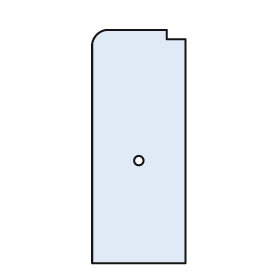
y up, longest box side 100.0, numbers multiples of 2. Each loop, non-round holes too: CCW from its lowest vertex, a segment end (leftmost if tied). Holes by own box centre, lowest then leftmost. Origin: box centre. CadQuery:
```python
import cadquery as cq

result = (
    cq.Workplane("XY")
    .moveTo(-20.0, -50.0)
    .lineTo(20.0, -50.0)
    .lineTo(20.0, 46.0)
    .lineTo(12.0, 46.0)
    .lineTo(12.0, 50.0)
    .lineTo(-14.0, 50.0)
    .threePointArc((-18.0, 48.0), (-20.0, 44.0))
    .close()
    .moveTo(0.0, -6.0)
    .circle(2.0)
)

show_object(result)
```